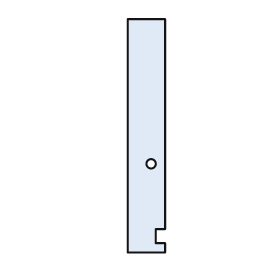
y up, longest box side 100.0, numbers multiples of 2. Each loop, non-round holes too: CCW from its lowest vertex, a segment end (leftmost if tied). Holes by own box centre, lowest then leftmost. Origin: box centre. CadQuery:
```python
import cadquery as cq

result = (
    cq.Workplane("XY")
    .moveTo(-8.0, -50.0)
    .lineTo(8.0, -50.0)
    .lineTo(8.0, -46.0)
    .lineTo(4.0, -46.0)
    .lineTo(4.0, -40.0)
    .lineTo(8.0, -40.0)
    .lineTo(8.0, 50.0)
    .lineTo(-8.0, 50.0)
    .close()
    .moveTo(2.0, -12.0)
    .circle(2.0)
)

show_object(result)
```